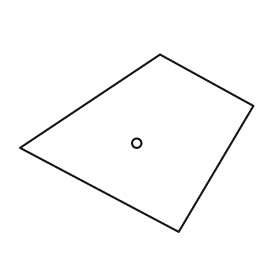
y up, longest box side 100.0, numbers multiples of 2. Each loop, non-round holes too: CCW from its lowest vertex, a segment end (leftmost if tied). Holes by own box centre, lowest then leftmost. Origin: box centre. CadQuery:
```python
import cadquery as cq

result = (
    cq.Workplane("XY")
    .moveTo(18.0, -38.0)
    .lineTo(50.0, 16.0)
    .lineTo(10.0, 38.0)
    .lineTo(-50.0, -2.0)
    .close()
    .moveTo(0.0, 0.0)
    .circle(2.0)
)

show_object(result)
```